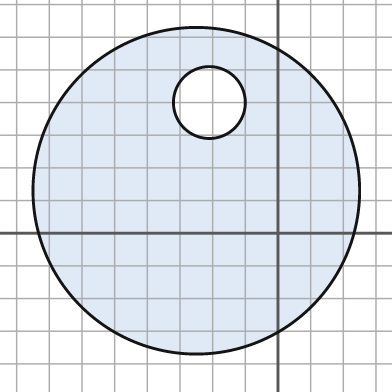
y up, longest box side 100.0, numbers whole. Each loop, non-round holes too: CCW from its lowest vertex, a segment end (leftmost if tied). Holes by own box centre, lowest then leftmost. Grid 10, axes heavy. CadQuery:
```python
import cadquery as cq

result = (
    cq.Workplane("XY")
    .moveTo(-25.0, 13.0)
    .circle(50.0)
    .moveTo(-21.0, 40.0)
    .circle(11.0)
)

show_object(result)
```